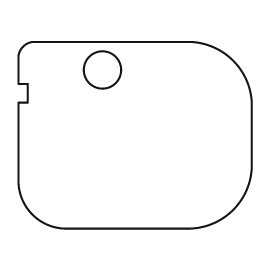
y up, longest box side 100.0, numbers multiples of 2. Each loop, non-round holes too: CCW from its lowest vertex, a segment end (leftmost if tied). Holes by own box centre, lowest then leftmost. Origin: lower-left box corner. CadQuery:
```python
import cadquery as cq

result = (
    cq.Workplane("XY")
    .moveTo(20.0, 0.0)
    .lineTo(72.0, 0.0)
    .threePointArc((92.0, 8.0), (100.0, 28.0))
    .lineTo(100.0, 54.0)
    .threePointArc((92.0, 72.0), (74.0, 80.0))
    .lineTo(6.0, 80.0)
    .threePointArc((2.0, 78.0), (0.0, 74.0))
    .lineTo(0.0, 62.0)
    .lineTo(4.0, 62.0)
    .lineTo(4.0, 54.0)
    .lineTo(0.0, 54.0)
    .lineTo(0.0, 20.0)
    .threePointArc((6.0, 6.0), (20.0, 0.0))
    .close()
    .moveTo(36.0, 68.0)
    .circle(8.0)
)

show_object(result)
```